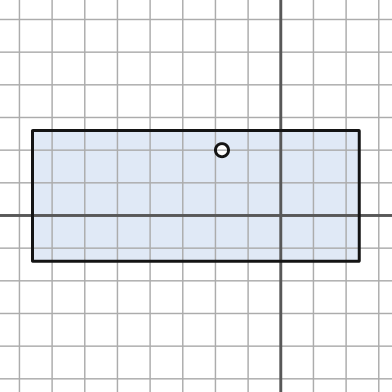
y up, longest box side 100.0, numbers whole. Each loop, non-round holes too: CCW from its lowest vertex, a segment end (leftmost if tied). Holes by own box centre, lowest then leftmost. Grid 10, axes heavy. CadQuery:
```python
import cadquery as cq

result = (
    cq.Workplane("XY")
    .moveTo(-76.0, -14.0)
    .lineTo(24.0, -14.0)
    .lineTo(24.0, 26.0)
    .lineTo(-76.0, 26.0)
    .close()
    .moveTo(-18.0, 20.0)
    .circle(2.0)
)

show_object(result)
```